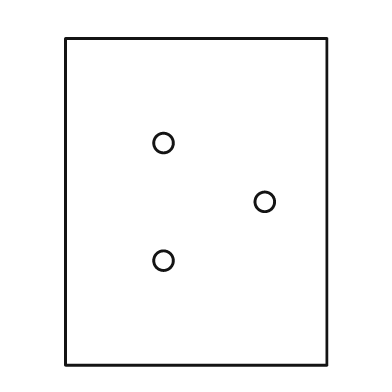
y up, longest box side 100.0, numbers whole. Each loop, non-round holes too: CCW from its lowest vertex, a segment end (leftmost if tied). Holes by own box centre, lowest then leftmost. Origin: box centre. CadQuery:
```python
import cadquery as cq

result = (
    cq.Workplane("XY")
    .moveTo(-40.0, -50.0)
    .lineTo(40.0, -50.0)
    .lineTo(40.0, 50.0)
    .lineTo(-40.0, 50.0)
    .close()
    .moveTo(-10.0, -18.0)
    .circle(3.0)
    .moveTo(21.0, 0.0)
    .circle(3.0)
    .moveTo(-10.0, 18.0)
    .circle(3.0)
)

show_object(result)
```